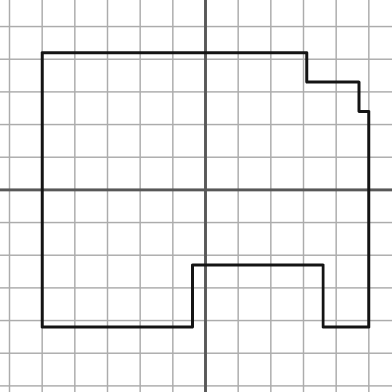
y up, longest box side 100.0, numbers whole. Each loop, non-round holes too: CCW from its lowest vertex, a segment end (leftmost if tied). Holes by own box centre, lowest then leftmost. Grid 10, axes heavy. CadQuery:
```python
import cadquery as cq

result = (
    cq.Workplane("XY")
    .moveTo(-50.0, -42.0)
    .lineTo(-4.0, -42.0)
    .lineTo(-4.0, -23.0)
    .lineTo(36.0, -23.0)
    .lineTo(36.0, -42.0)
    .lineTo(50.0, -42.0)
    .lineTo(50.0, 24.0)
    .lineTo(47.0, 24.0)
    .lineTo(47.0, 33.0)
    .lineTo(31.0, 33.0)
    .lineTo(31.0, 42.0)
    .lineTo(-50.0, 42.0)
    .close()
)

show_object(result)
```